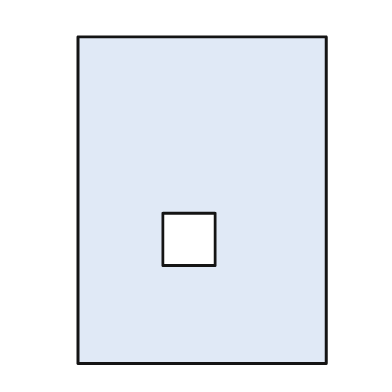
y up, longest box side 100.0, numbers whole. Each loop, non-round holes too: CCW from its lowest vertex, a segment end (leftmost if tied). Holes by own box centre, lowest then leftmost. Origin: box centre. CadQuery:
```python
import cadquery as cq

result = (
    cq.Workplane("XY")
    .moveTo(-38.0, -50.0)
    .lineTo(38.0, -50.0)
    .lineTo(38.0, 50.0)
    .lineTo(-38.0, 50.0)
    .close()
    .moveTo(-12.0, -20.0)
    .lineTo(4.0, -20.0)
    .lineTo(4.0, -4.0)
    .lineTo(-12.0, -4.0)
    .close()
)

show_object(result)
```